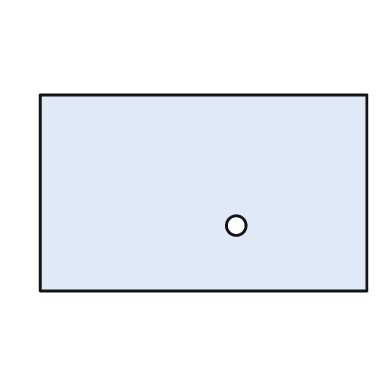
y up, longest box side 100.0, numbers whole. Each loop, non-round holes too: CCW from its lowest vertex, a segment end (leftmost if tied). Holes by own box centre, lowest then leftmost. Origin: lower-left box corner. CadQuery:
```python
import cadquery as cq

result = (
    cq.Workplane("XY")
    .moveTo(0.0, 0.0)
    .lineTo(100.0, 0.0)
    .lineTo(100.0, 60.0)
    .lineTo(0.0, 60.0)
    .close()
    .moveTo(60.0, 20.0)
    .circle(3.0)
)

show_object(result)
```